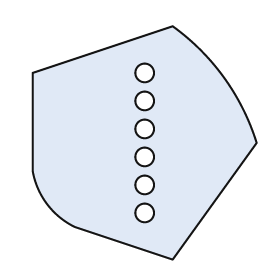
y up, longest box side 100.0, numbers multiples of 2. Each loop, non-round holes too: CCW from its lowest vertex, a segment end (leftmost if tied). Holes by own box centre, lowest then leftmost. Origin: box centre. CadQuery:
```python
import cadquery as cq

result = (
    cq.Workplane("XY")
    .moveTo(12.0, -50.0)
    .lineTo(48.0, 0.0)
    .threePointArc((34.0, 28.0), (12.0, 50.0))
    .lineTo(-48.0, 30.0)
    .lineTo(-48.0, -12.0)
    .threePointArc((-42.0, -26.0), (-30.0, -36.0))
    .close()
    .moveTo(0.0, -30.0)
    .circle(4.0)
    .moveTo(0.0, -18.0)
    .circle(4.0)
    .moveTo(0.0, -6.0)
    .circle(4.0)
    .moveTo(0.0, 6.0)
    .circle(4.0)
    .moveTo(0.0, 18.0)
    .circle(4.0)
    .moveTo(0.0, 30.0)
    .circle(4.0)
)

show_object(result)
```